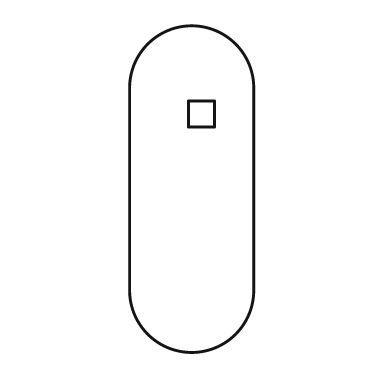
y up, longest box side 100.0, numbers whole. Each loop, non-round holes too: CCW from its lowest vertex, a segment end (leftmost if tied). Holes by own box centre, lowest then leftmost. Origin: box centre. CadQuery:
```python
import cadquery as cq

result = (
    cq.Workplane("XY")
    .moveTo(-19.0, -31.0)
    .threePointArc((0.0, -50.0), (19.0, -31.0))
    .lineTo(19.0, 31.0)
    .threePointArc((0.0, 50.0), (-19.0, 31.0))
    .close()
    .moveTo(-1.0, 19.0)
    .lineTo(7.0, 19.0)
    .lineTo(7.0, 27.0)
    .lineTo(-1.0, 27.0)
    .close()
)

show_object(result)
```